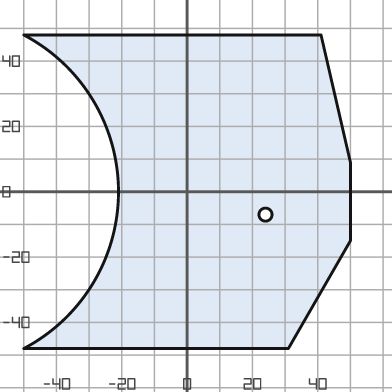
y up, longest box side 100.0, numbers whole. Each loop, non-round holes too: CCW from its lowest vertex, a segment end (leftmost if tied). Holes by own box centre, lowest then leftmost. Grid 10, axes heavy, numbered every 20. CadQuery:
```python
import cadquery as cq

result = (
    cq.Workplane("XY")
    .moveTo(-50.0, -48.0)
    .lineTo(31.0, -48.0)
    .lineTo(50.0, -15.0)
    .lineTo(50.0, 9.0)
    .lineTo(41.0, 48.0)
    .lineTo(-50.0, 48.0)
    .threePointArc((-21.0, 0.0), (-50.0, -48.0))
    .close()
    .moveTo(24.0, -7.0)
    .circle(2.0)
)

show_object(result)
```